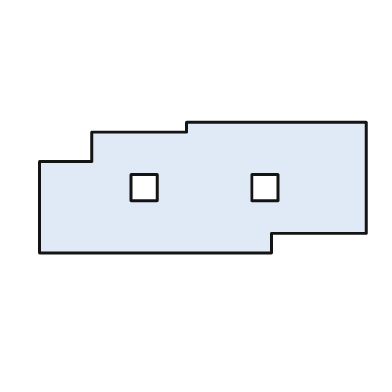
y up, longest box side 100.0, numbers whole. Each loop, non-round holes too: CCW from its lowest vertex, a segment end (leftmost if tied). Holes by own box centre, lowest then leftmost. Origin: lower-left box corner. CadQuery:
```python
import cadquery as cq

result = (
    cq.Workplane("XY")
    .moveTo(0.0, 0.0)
    .lineTo(71.0, 0.0)
    .lineTo(71.0, 6.0)
    .lineTo(100.0, 6.0)
    .lineTo(100.0, 40.0)
    .lineTo(45.0, 40.0)
    .lineTo(45.0, 37.0)
    .lineTo(16.0, 37.0)
    .lineTo(16.0, 28.0)
    .lineTo(0.0, 28.0)
    .close()
    .moveTo(28.0, 16.0)
    .lineTo(36.0, 16.0)
    .lineTo(36.0, 24.0)
    .lineTo(28.0, 24.0)
    .close()
    .moveTo(65.0, 16.0)
    .lineTo(73.0, 16.0)
    .lineTo(73.0, 24.0)
    .lineTo(65.0, 24.0)
    .close()
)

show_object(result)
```